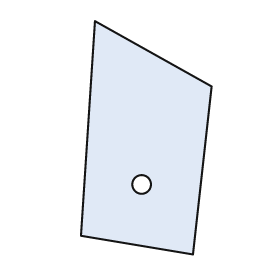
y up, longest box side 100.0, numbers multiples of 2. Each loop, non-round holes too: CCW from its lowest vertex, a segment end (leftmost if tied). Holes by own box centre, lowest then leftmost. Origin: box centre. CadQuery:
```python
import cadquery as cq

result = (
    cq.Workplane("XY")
    .moveTo(20.0, -50.0)
    .lineTo(28.0, 22.0)
    .lineTo(-22.0, 50.0)
    .lineTo(-28.0, -42.0)
    .close()
    .moveTo(-2.0, -20.0)
    .circle(4.0)
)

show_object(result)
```